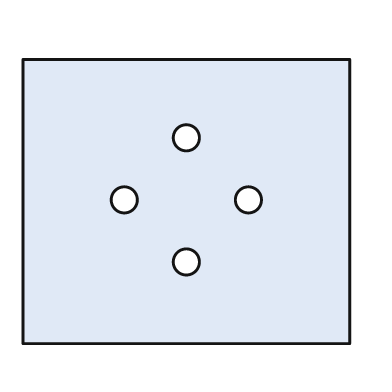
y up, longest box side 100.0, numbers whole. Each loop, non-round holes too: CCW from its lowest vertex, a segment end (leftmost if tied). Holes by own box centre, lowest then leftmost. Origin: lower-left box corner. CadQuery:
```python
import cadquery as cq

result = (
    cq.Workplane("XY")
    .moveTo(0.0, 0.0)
    .lineTo(100.0, 0.0)
    .lineTo(100.0, 87.0)
    .lineTo(0.0, 87.0)
    .close()
    .moveTo(50.0, 25.0)
    .circle(4.0)
    .moveTo(31.0, 44.0)
    .circle(4.0)
    .moveTo(69.0, 44.0)
    .circle(4.0)
    .moveTo(50.0, 63.0)
    .circle(4.0)
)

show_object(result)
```